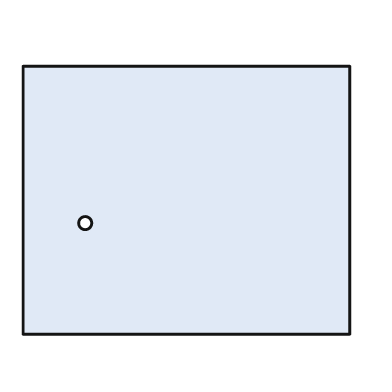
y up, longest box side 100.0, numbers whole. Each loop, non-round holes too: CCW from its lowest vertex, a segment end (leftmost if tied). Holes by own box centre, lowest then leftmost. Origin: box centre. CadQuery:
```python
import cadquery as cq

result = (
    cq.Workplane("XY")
    .moveTo(-50.0, -41.0)
    .lineTo(50.0, -41.0)
    .lineTo(50.0, 41.0)
    .lineTo(-50.0, 41.0)
    .close()
    .moveTo(-31.0, -7.0)
    .circle(2.0)
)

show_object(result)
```